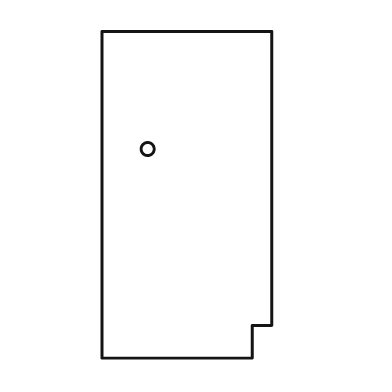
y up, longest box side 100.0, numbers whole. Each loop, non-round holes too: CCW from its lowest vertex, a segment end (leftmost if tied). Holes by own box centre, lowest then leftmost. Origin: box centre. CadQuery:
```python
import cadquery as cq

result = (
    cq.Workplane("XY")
    .moveTo(-26.0, -50.0)
    .lineTo(20.0, -50.0)
    .lineTo(20.0, -40.0)
    .lineTo(26.0, -40.0)
    .lineTo(26.0, 50.0)
    .lineTo(-26.0, 50.0)
    .close()
    .moveTo(-12.0, 14.0)
    .circle(2.0)
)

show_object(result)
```